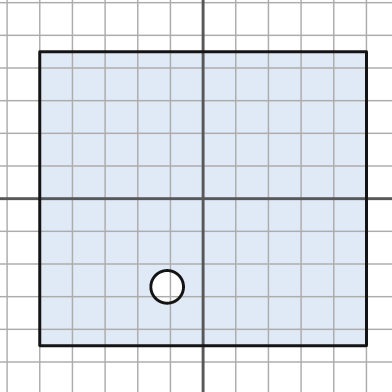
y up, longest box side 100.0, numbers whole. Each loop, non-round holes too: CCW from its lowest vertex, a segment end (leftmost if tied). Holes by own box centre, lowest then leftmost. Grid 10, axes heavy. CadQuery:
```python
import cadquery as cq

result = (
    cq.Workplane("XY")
    .moveTo(-50.0, -45.0)
    .lineTo(50.0, -45.0)
    .lineTo(50.0, 45.0)
    .lineTo(-50.0, 45.0)
    .close()
    .moveTo(-11.0, -27.0)
    .circle(5.0)
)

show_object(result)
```